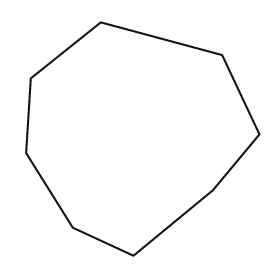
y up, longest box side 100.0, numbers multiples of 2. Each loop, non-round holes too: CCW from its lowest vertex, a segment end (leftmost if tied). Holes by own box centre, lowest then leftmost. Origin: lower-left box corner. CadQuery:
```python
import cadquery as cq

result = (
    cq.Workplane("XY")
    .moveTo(46.0, 0.0)
    .lineTo(80.0, 28.0)
    .lineTo(100.0, 52.0)
    .lineTo(84.0, 86.0)
    .lineTo(32.0, 100.0)
    .lineTo(2.0, 76.0)
    .lineTo(0.0, 44.0)
    .lineTo(20.0, 12.0)
    .close()
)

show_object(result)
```